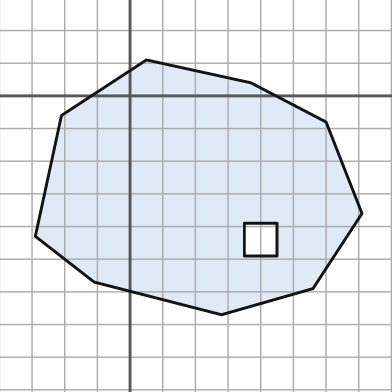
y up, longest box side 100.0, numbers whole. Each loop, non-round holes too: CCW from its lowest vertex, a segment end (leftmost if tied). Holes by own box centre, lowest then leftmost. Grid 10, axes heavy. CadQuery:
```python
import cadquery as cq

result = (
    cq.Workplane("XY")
    .moveTo(28.0, -67.0)
    .lineTo(56.0, -59.0)
    .lineTo(71.0, -36.0)
    .lineTo(60.0, -8.0)
    .lineTo(37.0, 4.0)
    .lineTo(5.0, 11.0)
    .lineTo(-21.0, -6.0)
    .lineTo(-29.0, -43.0)
    .lineTo(-11.0, -57.0)
    .close()
    .moveTo(35.0, -49.0)
    .lineTo(45.0, -49.0)
    .lineTo(45.0, -39.0)
    .lineTo(35.0, -39.0)
    .close()
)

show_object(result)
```